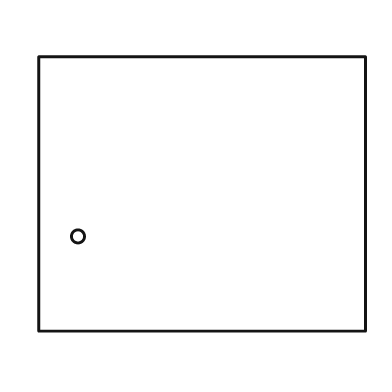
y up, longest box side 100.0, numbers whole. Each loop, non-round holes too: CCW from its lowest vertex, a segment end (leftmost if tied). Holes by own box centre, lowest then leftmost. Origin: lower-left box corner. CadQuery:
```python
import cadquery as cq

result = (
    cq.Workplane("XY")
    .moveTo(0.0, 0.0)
    .lineTo(100.0, 0.0)
    .lineTo(100.0, 84.0)
    .lineTo(0.0, 84.0)
    .close()
    .moveTo(12.0, 29.0)
    .circle(2.0)
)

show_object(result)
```